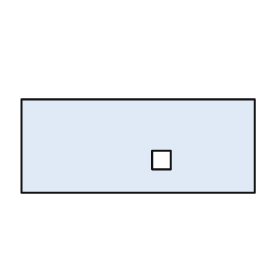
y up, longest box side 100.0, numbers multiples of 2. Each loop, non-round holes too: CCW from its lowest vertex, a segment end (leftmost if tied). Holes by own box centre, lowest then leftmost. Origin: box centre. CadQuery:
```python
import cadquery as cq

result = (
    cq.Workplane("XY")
    .moveTo(-50.0, -20.0)
    .lineTo(50.0, -20.0)
    .lineTo(50.0, 20.0)
    .lineTo(-50.0, 20.0)
    .close()
    .moveTo(6.0, -10.0)
    .lineTo(14.0, -10.0)
    .lineTo(14.0, -2.0)
    .lineTo(6.0, -2.0)
    .close()
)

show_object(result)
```